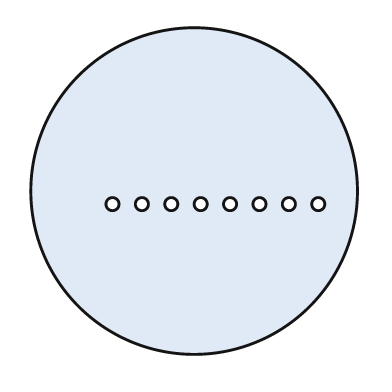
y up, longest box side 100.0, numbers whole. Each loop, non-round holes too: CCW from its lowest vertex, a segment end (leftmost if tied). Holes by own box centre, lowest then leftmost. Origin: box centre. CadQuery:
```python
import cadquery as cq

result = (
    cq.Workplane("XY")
    .moveTo(0.0, 0.0)
    .circle(50.0)
    .moveTo(-25.0, -4.0)
    .circle(2.0)
    .moveTo(-16.0, -4.0)
    .circle(2.0)
    .moveTo(-7.0, -4.0)
    .circle(2.0)
    .moveTo(2.0, -4.0)
    .circle(2.0)
    .moveTo(11.0, -4.0)
    .circle(2.0)
    .moveTo(20.0, -4.0)
    .circle(2.0)
    .moveTo(29.0, -4.0)
    .circle(2.0)
    .moveTo(38.0, -4.0)
    .circle(2.0)
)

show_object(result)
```